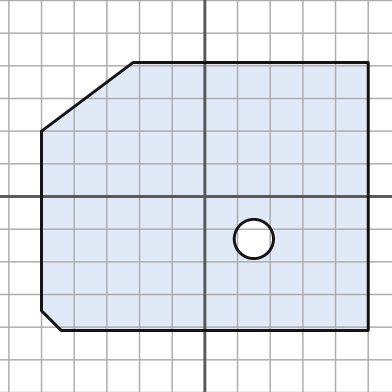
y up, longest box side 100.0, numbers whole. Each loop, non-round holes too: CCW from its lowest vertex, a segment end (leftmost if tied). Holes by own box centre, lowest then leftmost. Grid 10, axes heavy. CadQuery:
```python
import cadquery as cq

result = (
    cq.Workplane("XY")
    .moveTo(-44.0, -41.0)
    .lineTo(50.0, -41.0)
    .lineTo(50.0, 41.0)
    .lineTo(-22.0, 41.0)
    .lineTo(-50.0, 20.0)
    .lineTo(-50.0, -35.0)
    .close()
    .moveTo(15.0, -13.0)
    .circle(6.0)
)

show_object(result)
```